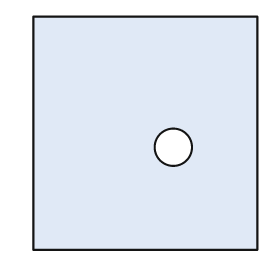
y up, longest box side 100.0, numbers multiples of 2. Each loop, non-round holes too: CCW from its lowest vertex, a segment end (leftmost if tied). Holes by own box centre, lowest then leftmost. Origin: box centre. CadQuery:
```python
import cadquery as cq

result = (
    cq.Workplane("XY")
    .moveTo(-48.0, -50.0)
    .lineTo(48.0, -50.0)
    .lineTo(48.0, 50.0)
    .lineTo(-48.0, 50.0)
    .close()
    .moveTo(12.0, -6.0)
    .circle(8.0)
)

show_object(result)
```